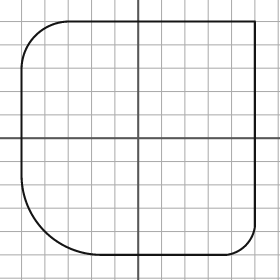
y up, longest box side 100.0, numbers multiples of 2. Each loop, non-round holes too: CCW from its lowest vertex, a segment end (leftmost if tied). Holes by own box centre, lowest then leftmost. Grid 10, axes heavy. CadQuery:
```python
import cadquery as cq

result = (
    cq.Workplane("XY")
    .moveTo(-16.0, -50.0)
    .lineTo(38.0, -50.0)
    .threePointArc((46.0, -46.0), (50.0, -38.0))
    .lineTo(50.0, 50.0)
    .lineTo(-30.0, 50.0)
    .threePointArc((-44.0, 44.0), (-50.0, 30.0))
    .lineTo(-50.0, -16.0)
    .threePointArc((-40.0, -40.0), (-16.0, -50.0))
    .close()
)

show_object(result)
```